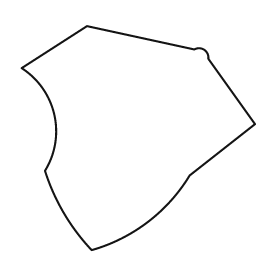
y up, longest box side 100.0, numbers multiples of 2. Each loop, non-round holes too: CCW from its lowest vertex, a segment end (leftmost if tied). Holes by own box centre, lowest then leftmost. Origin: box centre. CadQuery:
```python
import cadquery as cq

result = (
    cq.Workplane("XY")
    .moveTo(-20.0, -48.0)
    .threePointArc((4.0, -36.0), (22.0, -16.0))
    .lineTo(50.0, 6.0)
    .lineTo(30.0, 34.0)
    .threePointArc((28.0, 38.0), (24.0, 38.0))
    .lineTo(-22.0, 48.0)
    .lineTo(-50.0, 30.0)
    .threePointArc((-36.0, 10.0), (-40.0, -14.0))
    .threePointArc((-32.0, -32.0), (-20.0, -48.0))
    .close()
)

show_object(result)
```